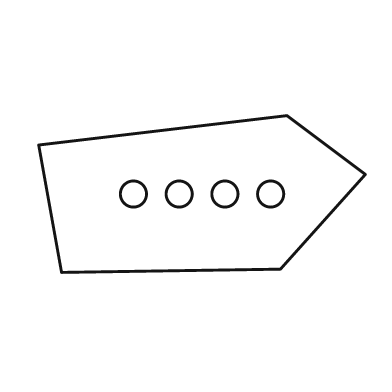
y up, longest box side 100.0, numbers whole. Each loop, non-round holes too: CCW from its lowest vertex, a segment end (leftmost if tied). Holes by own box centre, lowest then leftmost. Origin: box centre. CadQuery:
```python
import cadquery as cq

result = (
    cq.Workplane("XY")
    .moveTo(-43.0, -24.0)
    .lineTo(24.0, -23.0)
    .lineTo(50.0, 6.0)
    .lineTo(26.0, 24.0)
    .lineTo(-50.0, 15.0)
    .close()
    .moveTo(-21.0, 0.0)
    .circle(4.0)
    .moveTo(-7.0, 0.0)
    .circle(4.0)
    .moveTo(7.0, 0.0)
    .circle(4.0)
    .moveTo(21.0, 0.0)
    .circle(4.0)
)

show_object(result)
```